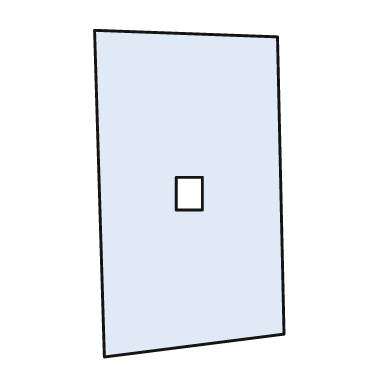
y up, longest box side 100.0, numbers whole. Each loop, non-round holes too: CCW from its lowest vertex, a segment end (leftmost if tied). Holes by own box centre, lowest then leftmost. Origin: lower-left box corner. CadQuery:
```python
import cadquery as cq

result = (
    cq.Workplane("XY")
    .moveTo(3.0, 0.0)
    .lineTo(58.0, 7.0)
    .lineTo(56.0, 98.0)
    .lineTo(0.0, 100.0)
    .close()
    .moveTo(25.0, 45.0)
    .lineTo(33.0, 45.0)
    .lineTo(33.0, 55.0)
    .lineTo(25.0, 55.0)
    .close()
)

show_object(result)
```